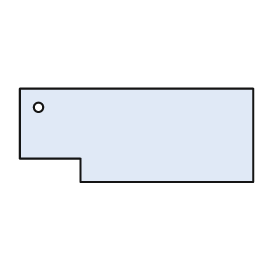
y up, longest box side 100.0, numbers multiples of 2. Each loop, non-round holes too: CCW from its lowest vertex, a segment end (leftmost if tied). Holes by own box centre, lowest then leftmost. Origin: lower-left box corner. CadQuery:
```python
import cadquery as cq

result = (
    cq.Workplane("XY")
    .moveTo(26.0, 0.0)
    .lineTo(100.0, 0.0)
    .lineTo(100.0, 40.0)
    .lineTo(0.0, 40.0)
    .lineTo(0.0, 10.0)
    .lineTo(26.0, 10.0)
    .close()
    .moveTo(8.0, 32.0)
    .circle(2.0)
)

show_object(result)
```